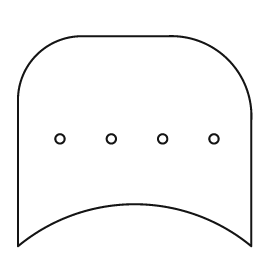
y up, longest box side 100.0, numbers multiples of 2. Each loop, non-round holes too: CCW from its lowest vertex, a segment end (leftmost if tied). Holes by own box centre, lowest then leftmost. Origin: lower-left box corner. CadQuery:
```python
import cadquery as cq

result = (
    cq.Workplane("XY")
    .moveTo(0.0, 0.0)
    .threePointArc((50.0, 18.0), (100.0, 0.0))
    .lineTo(100.0, 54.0)
    .threePointArc((90.0, 80.0), (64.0, 90.0))
    .lineTo(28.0, 90.0)
    .threePointArc((8.0, 82.0), (0.0, 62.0))
    .close()
    .moveTo(18.0, 46.0)
    .circle(2.0)
    .moveTo(40.0, 46.0)
    .circle(2.0)
    .moveTo(62.0, 46.0)
    .circle(2.0)
    .moveTo(84.0, 46.0)
    .circle(2.0)
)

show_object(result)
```